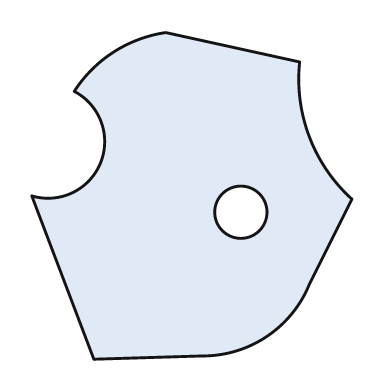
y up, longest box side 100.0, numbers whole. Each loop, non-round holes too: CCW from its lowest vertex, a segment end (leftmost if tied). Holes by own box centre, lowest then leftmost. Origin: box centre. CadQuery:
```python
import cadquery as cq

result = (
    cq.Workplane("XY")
    .moveTo(-30.0, -50.0)
    .lineTo(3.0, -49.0)
    .threePointArc((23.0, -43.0), (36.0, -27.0))
    .lineTo(49.0, -1.0)
    .threePointArc((36.0, 18.0), (33.0, 41.0))
    .lineTo(-8.0, 50.0)
    .threePointArc((-24.0, 44.0), (-36.0, 32.0))
    .threePointArc((-28.0, 10.0), (-49.0, 0.0))
    .close()
    .moveTo(15.0, -5.0)
    .circle(8.0)
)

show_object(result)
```